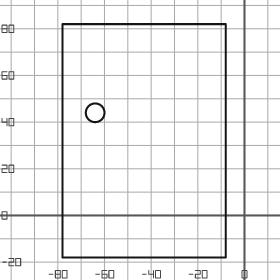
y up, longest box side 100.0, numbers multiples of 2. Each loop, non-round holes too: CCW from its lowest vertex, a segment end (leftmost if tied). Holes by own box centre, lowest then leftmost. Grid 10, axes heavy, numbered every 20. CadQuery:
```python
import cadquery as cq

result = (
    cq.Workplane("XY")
    .moveTo(-78.0, -18.0)
    .lineTo(-8.0, -18.0)
    .lineTo(-8.0, 82.0)
    .lineTo(-78.0, 82.0)
    .close()
    .moveTo(-64.0, 44.0)
    .circle(4.0)
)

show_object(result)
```